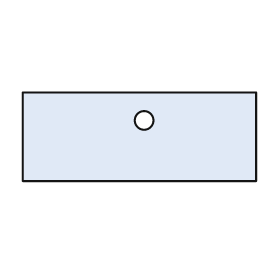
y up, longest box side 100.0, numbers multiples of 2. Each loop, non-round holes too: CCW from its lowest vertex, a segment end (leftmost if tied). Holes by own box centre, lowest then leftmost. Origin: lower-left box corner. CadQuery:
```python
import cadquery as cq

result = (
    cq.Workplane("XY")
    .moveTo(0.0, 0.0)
    .lineTo(100.0, 0.0)
    .lineTo(100.0, 38.0)
    .lineTo(0.0, 38.0)
    .close()
    .moveTo(52.0, 26.0)
    .circle(4.0)
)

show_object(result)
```